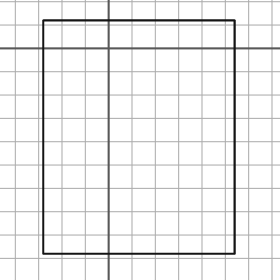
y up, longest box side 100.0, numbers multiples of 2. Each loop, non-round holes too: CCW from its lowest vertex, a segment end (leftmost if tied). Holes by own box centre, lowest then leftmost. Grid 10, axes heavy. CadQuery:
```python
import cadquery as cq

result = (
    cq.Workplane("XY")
    .moveTo(-28.0, -88.0)
    .lineTo(54.0, -88.0)
    .lineTo(54.0, 12.0)
    .lineTo(-28.0, 12.0)
    .close()
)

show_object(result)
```